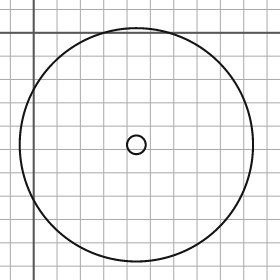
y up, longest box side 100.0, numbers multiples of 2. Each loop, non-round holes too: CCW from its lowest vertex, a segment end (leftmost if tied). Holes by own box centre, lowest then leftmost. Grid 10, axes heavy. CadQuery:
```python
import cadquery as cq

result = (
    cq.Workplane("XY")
    .moveTo(44.0, -48.0)
    .circle(50.0)
    .moveTo(44.0, -48.0)
    .circle(4.0)
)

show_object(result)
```